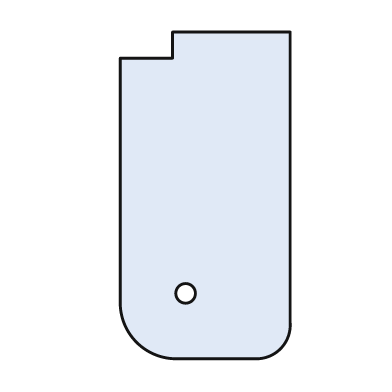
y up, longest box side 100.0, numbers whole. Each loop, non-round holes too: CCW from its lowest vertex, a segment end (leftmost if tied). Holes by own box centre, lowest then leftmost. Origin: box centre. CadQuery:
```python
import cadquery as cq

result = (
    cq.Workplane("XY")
    .moveTo(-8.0, -50.0)
    .lineTo(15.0, -50.0)
    .threePointArc((23.0, -47.0), (26.0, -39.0))
    .lineTo(26.0, 50.0)
    .lineTo(-10.0, 50.0)
    .lineTo(-10.0, 42.0)
    .lineTo(-26.0, 42.0)
    .lineTo(-26.0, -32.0)
    .threePointArc((-21.0, -45.0), (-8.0, -50.0))
    .close()
    .moveTo(-6.0, -30.0)
    .circle(3.0)
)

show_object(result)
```